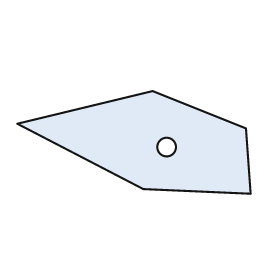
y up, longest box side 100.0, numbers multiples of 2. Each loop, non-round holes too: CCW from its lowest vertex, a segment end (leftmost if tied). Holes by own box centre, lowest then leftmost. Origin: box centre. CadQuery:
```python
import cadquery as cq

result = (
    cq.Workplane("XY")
    .moveTo(50.0, -22.0)
    .lineTo(48.0, 6.0)
    .lineTo(8.0, 22.0)
    .lineTo(-50.0, 8.0)
    .lineTo(4.0, -20.0)
    .close()
    .moveTo(14.0, -2.0)
    .circle(4.0)
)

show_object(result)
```